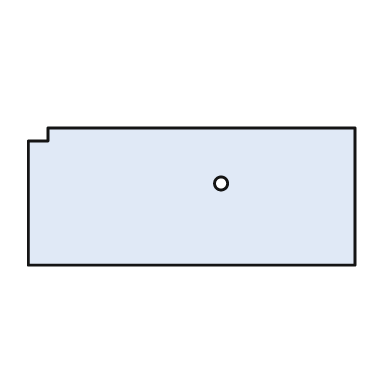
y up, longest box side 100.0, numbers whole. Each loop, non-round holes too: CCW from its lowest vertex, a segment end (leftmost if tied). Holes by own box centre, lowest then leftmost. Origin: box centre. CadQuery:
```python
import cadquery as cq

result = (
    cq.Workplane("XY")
    .moveTo(-50.0, -21.0)
    .lineTo(50.0, -21.0)
    .lineTo(50.0, 21.0)
    .lineTo(-44.0, 21.0)
    .lineTo(-44.0, 17.0)
    .lineTo(-50.0, 17.0)
    .close()
    .moveTo(9.0, 4.0)
    .circle(2.0)
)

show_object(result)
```